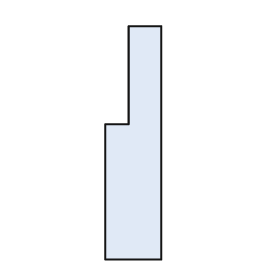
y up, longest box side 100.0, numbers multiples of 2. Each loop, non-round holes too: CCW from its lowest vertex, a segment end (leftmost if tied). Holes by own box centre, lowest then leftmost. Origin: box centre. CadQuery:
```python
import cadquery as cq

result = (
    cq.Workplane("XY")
    .moveTo(-12.0, -50.0)
    .lineTo(12.0, -50.0)
    .lineTo(12.0, 50.0)
    .lineTo(-2.0, 50.0)
    .lineTo(-2.0, 8.0)
    .lineTo(-12.0, 8.0)
    .close()
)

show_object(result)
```